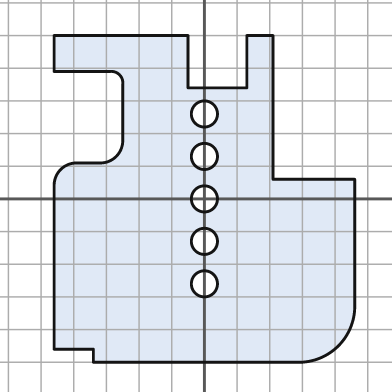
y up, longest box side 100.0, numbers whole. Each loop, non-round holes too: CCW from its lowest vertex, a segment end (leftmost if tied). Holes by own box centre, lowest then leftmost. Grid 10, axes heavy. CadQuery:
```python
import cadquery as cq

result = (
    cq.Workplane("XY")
    .moveTo(-34.0, -50.0)
    .lineTo(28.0, -50.0)
    .threePointArc((41.0, -45.0), (46.0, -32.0))
    .lineTo(46.0, 6.0)
    .lineTo(21.0, 6.0)
    .lineTo(21.0, 50.0)
    .lineTo(13.0, 50.0)
    .lineTo(13.0, 34.0)
    .lineTo(-5.0, 34.0)
    .lineTo(-5.0, 50.0)
    .lineTo(-46.0, 50.0)
    .lineTo(-46.0, 39.0)
    .lineTo(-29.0, 39.0)
    .threePointArc((-26.0, 38.0), (-25.0, 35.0))
    .lineTo(-25.0, 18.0)
    .threePointArc((-27.0, 13.0), (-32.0, 11.0))
    .lineTo(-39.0, 11.0)
    .threePointArc((-44.0, 9.0), (-46.0, 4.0))
    .lineTo(-46.0, -46.0)
    .lineTo(-34.0, -46.0)
    .close()
    .moveTo(0.0, -26.0)
    .circle(4.0)
    .moveTo(0.0, -13.0)
    .circle(4.0)
    .moveTo(0.0, 0.0)
    .circle(4.0)
    .moveTo(0.0, 13.0)
    .circle(4.0)
    .moveTo(0.0, 26.0)
    .circle(4.0)
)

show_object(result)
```